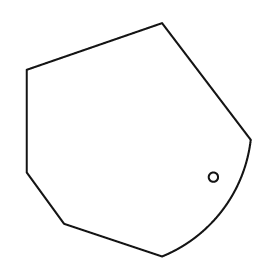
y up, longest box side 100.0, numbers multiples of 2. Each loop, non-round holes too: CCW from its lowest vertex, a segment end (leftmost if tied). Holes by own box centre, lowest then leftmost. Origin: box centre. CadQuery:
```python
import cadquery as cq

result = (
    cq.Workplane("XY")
    .moveTo(10.0, -50.0)
    .threePointArc((36.0, -30.0), (48.0, 0.0))
    .lineTo(10.0, 50.0)
    .lineTo(-48.0, 30.0)
    .lineTo(-48.0, -14.0)
    .lineTo(-32.0, -36.0)
    .close()
    .moveTo(32.0, -16.0)
    .circle(2.0)
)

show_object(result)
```